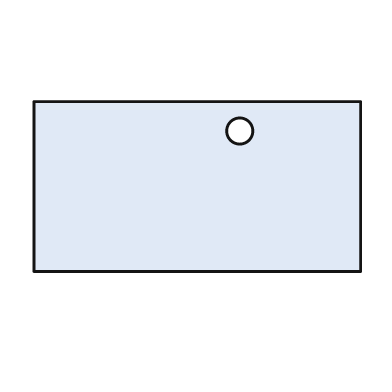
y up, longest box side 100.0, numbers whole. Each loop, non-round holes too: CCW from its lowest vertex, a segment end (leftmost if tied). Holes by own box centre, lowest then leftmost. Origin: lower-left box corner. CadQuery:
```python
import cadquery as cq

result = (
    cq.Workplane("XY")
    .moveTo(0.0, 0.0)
    .lineTo(100.0, 0.0)
    .lineTo(100.0, 52.0)
    .lineTo(0.0, 52.0)
    .close()
    .moveTo(63.0, 43.0)
    .circle(4.0)
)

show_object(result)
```